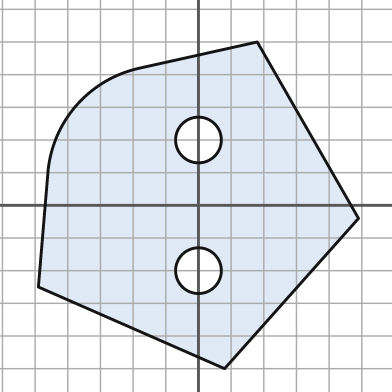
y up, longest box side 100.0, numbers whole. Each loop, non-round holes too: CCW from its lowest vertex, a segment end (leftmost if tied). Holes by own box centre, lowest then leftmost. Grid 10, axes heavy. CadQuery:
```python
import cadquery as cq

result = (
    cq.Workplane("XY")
    .moveTo(8.0, -50.0)
    .lineTo(49.0, -4.0)
    .lineTo(18.0, 50.0)
    .lineTo(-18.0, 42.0)
    .threePointArc((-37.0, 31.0), (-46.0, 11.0))
    .lineTo(-49.0, -25.0)
    .close()
    .moveTo(0.0, -20.0)
    .circle(7.0)
    .moveTo(0.0, 20.0)
    .circle(7.0)
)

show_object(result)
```